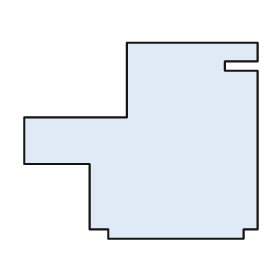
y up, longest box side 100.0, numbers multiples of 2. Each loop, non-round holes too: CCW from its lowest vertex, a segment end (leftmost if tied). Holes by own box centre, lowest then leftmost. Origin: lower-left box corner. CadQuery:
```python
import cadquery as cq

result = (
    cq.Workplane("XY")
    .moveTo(36.0, 0.0)
    .lineTo(94.0, 0.0)
    .lineTo(94.0, 4.0)
    .lineTo(100.0, 4.0)
    .lineTo(100.0, 72.0)
    .lineTo(86.0, 72.0)
    .lineTo(86.0, 76.0)
    .lineTo(100.0, 76.0)
    .lineTo(100.0, 84.0)
    .lineTo(44.0, 84.0)
    .lineTo(44.0, 52.0)
    .lineTo(0.0, 52.0)
    .lineTo(0.0, 32.0)
    .lineTo(28.0, 32.0)
    .lineTo(28.0, 4.0)
    .lineTo(36.0, 4.0)
    .close()
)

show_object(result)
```